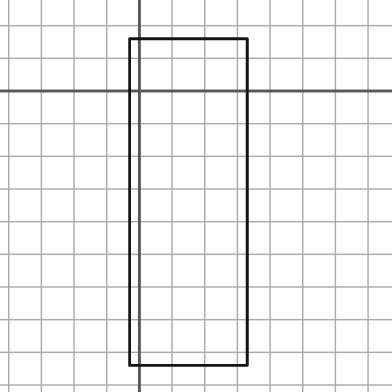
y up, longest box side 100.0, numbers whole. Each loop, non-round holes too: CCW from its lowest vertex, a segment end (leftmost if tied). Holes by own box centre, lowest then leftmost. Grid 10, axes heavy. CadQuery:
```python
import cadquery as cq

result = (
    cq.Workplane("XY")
    .moveTo(-3.0, -84.0)
    .lineTo(33.0, -84.0)
    .lineTo(33.0, 16.0)
    .lineTo(-3.0, 16.0)
    .close()
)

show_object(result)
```